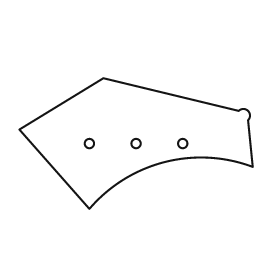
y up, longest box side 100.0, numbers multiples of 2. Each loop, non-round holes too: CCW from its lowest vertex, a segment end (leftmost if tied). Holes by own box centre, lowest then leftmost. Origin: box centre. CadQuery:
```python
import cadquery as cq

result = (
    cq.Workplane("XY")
    .moveTo(-20.0, -28.0)
    .threePointArc((12.0, -8.0), (50.0, -10.0))
    .lineTo(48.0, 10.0)
    .threePointArc((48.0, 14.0), (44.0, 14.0))
    .lineTo(-14.0, 28.0)
    .lineTo(-50.0, 6.0)
    .close()
    .moveTo(-20.0, 0.0)
    .circle(2.0)
    .moveTo(0.0, 0.0)
    .circle(2.0)
    .moveTo(20.0, 0.0)
    .circle(2.0)
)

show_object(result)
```